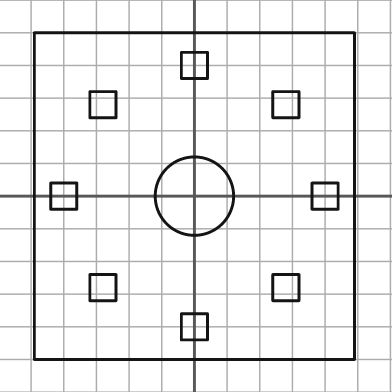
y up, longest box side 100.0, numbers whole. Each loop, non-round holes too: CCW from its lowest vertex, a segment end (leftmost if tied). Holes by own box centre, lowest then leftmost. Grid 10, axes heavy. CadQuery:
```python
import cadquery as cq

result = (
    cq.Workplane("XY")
    .moveTo(-49.0, -50.0)
    .lineTo(49.0, -50.0)
    .lineTo(49.0, 50.0)
    .lineTo(-49.0, 50.0)
    .close()
    .moveTo(-4.0, -44.0)
    .lineTo(4.0, -44.0)
    .lineTo(4.0, -36.0)
    .lineTo(-4.0, -36.0)
    .close()
    .moveTo(-32.0, -32.0)
    .lineTo(-24.0, -32.0)
    .lineTo(-24.0, -24.0)
    .lineTo(-32.0, -24.0)
    .close()
    .moveTo(24.0, -32.0)
    .lineTo(32.0, -32.0)
    .lineTo(32.0, -24.0)
    .lineTo(24.0, -24.0)
    .close()
    .moveTo(-44.0, -4.0)
    .lineTo(-36.0, -4.0)
    .lineTo(-36.0, 4.0)
    .lineTo(-44.0, 4.0)
    .close()
    .moveTo(0.0, 0.0)
    .circle(12.0)
    .moveTo(36.0, -4.0)
    .lineTo(44.0, -4.0)
    .lineTo(44.0, 4.0)
    .lineTo(36.0, 4.0)
    .close()
    .moveTo(-32.0, 24.0)
    .lineTo(-24.0, 24.0)
    .lineTo(-24.0, 32.0)
    .lineTo(-32.0, 32.0)
    .close()
    .moveTo(24.0, 24.0)
    .lineTo(32.0, 24.0)
    .lineTo(32.0, 32.0)
    .lineTo(24.0, 32.0)
    .close()
    .moveTo(-4.0, 36.0)
    .lineTo(4.0, 36.0)
    .lineTo(4.0, 44.0)
    .lineTo(-4.0, 44.0)
    .close()
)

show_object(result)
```